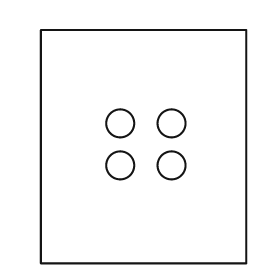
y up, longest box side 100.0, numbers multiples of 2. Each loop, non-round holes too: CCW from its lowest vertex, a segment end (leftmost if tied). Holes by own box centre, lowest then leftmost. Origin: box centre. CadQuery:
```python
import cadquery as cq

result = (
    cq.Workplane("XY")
    .moveTo(-44.0, -50.0)
    .lineTo(44.0, -50.0)
    .lineTo(44.0, 50.0)
    .lineTo(-44.0, 50.0)
    .close()
    .moveTo(-10.0, -8.0)
    .circle(6.0)
    .moveTo(12.0, -8.0)
    .circle(6.0)
    .moveTo(-10.0, 10.0)
    .circle(6.0)
    .moveTo(12.0, 10.0)
    .circle(6.0)
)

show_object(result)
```